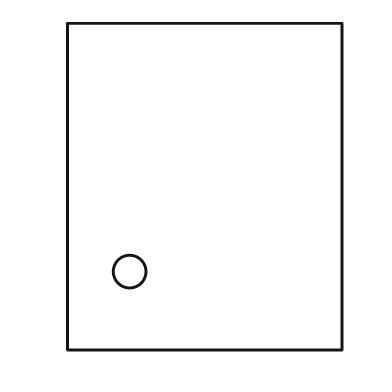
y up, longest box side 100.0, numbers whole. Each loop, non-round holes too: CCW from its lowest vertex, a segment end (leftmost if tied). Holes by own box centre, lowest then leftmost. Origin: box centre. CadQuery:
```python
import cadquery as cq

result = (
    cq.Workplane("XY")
    .moveTo(-42.0, -50.0)
    .lineTo(42.0, -50.0)
    .lineTo(42.0, 50.0)
    .lineTo(-42.0, 50.0)
    .close()
    .moveTo(-23.0, -26.0)
    .circle(5.0)
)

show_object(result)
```